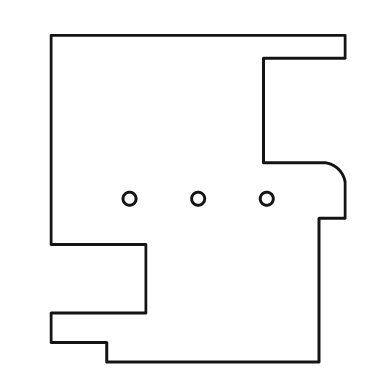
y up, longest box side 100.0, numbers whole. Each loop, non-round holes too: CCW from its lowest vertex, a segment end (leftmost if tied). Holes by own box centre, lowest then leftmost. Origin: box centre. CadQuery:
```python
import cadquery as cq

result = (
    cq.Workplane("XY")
    .moveTo(-28.0, -50.0)
    .lineTo(37.0, -50.0)
    .lineTo(37.0, -6.0)
    .lineTo(45.0, -6.0)
    .lineTo(45.0, 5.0)
    .threePointArc((43.0, 9.0), (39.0, 11.0))
    .lineTo(20.0, 11.0)
    .lineTo(20.0, 43.0)
    .lineTo(45.0, 43.0)
    .lineTo(45.0, 50.0)
    .lineTo(-45.0, 50.0)
    .lineTo(-45.0, -14.0)
    .lineTo(-16.0, -14.0)
    .lineTo(-16.0, -35.0)
    .lineTo(-45.0, -35.0)
    .lineTo(-45.0, -44.0)
    .lineTo(-28.0, -44.0)
    .close()
    .moveTo(-21.0, 0.0)
    .circle(2.0)
    .moveTo(0.0, 0.0)
    .circle(2.0)
    .moveTo(21.0, 0.0)
    .circle(2.0)
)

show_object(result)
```